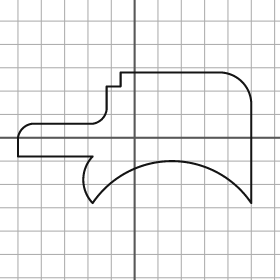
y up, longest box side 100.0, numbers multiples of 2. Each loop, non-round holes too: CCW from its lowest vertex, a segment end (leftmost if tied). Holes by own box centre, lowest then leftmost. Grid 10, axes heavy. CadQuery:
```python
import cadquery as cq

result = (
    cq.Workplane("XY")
    .moveTo(-18.0, -28.0)
    .threePointArc((16.0, -10.0), (50.0, -28.0))
    .lineTo(50.0, 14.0)
    .threePointArc((46.0, 24.0), (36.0, 28.0))
    .lineTo(-6.0, 28.0)
    .lineTo(-6.0, 22.0)
    .lineTo(-12.0, 22.0)
    .lineTo(-12.0, 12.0)
    .threePointArc((-14.0, 8.0), (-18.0, 6.0))
    .lineTo(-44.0, 6.0)
    .threePointArc((-48.0, 4.0), (-50.0, 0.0))
    .lineTo(-50.0, -8.0)
    .lineTo(-18.0, -8.0)
    .threePointArc((-22.0, -18.0), (-18.0, -28.0))
    .close()
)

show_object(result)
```